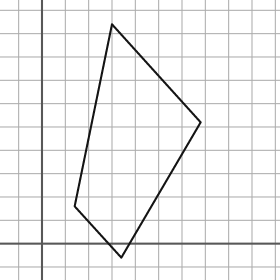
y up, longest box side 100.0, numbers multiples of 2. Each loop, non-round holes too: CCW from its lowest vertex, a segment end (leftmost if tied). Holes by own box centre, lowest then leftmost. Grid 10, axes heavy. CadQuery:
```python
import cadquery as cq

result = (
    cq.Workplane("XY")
    .moveTo(34.0, -6.0)
    .lineTo(68.0, 52.0)
    .lineTo(30.0, 94.0)
    .lineTo(14.0, 16.0)
    .close()
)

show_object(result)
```